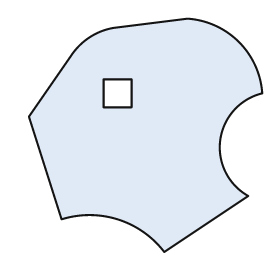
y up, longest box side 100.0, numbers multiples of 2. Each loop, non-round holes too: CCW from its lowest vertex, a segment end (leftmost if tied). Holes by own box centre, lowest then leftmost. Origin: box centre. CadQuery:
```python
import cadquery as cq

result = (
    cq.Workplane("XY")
    .moveTo(8.0, -50.0)
    .lineTo(44.0, -26.0)
    .threePointArc((32.0, -2.0), (50.0, 18.0))
    .threePointArc((40.0, 40.0), (18.0, 50.0))
    .lineTo(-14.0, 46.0)
    .threePointArc((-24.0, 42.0), (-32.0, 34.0))
    .lineTo(-50.0, 8.0)
    .lineTo(-36.0, -36.0)
    .threePointArc((-12.0, -36.0), (8.0, -50.0))
    .close()
    .moveTo(-18.0, 12.0)
    .lineTo(-6.0, 12.0)
    .lineTo(-6.0, 24.0)
    .lineTo(-18.0, 24.0)
    .close()
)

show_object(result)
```